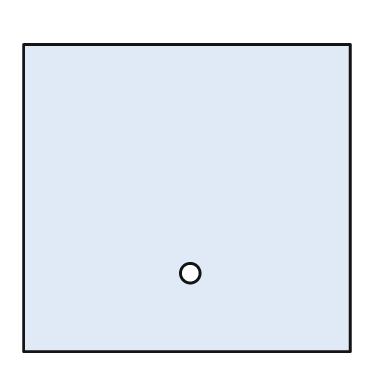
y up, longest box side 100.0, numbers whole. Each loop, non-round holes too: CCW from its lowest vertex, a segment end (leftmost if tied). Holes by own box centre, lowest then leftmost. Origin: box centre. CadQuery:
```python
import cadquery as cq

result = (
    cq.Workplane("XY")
    .moveTo(-50.0, -47.0)
    .lineTo(50.0, -47.0)
    .lineTo(50.0, 47.0)
    .lineTo(-50.0, 47.0)
    .close()
    .moveTo(1.0, -23.0)
    .circle(3.0)
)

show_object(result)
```